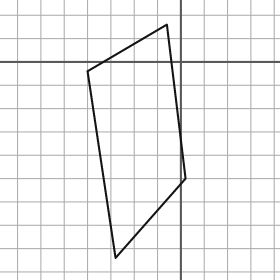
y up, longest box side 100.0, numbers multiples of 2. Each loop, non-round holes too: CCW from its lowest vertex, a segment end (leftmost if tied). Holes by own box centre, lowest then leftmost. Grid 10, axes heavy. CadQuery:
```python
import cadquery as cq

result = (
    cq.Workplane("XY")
    .moveTo(-28.0, -84.0)
    .lineTo(2.0, -50.0)
    .lineTo(-6.0, 16.0)
    .lineTo(-40.0, -4.0)
    .close()
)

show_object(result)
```